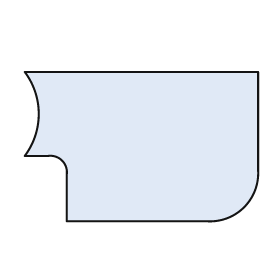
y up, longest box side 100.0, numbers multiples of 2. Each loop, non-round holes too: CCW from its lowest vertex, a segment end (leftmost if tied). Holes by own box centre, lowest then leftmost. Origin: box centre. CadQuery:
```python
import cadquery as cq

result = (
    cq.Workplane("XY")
    .moveTo(-32.0, -32.0)
    .lineTo(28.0, -32.0)
    .threePointArc((44.0, -26.0), (50.0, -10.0))
    .lineTo(50.0, 32.0)
    .lineTo(-50.0, 32.0)
    .threePointArc((-44.0, 14.0), (-50.0, -4.0))
    .lineTo(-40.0, -4.0)
    .threePointArc((-34.0, -6.0), (-32.0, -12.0))
    .close()
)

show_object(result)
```